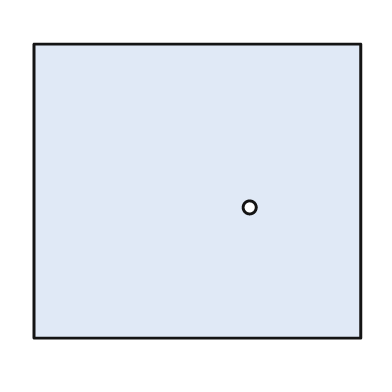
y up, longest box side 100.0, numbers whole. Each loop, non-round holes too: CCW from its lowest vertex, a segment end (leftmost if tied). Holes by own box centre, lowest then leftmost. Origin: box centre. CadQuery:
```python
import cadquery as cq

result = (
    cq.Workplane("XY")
    .moveTo(-50.0, -45.0)
    .lineTo(50.0, -45.0)
    .lineTo(50.0, 45.0)
    .lineTo(-50.0, 45.0)
    .close()
    .moveTo(16.0, -5.0)
    .circle(2.0)
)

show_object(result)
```